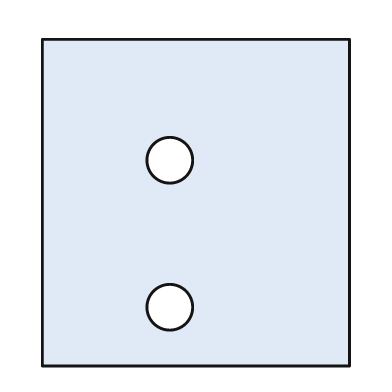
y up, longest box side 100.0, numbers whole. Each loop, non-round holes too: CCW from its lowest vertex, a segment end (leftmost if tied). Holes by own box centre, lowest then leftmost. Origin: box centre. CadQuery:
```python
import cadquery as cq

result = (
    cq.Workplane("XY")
    .moveTo(-47.0, -50.0)
    .lineTo(47.0, -50.0)
    .lineTo(47.0, 50.0)
    .lineTo(-47.0, 50.0)
    .close()
    .moveTo(-8.0, -32.0)
    .circle(7.0)
    .moveTo(-8.0, 13.0)
    .circle(7.0)
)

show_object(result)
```